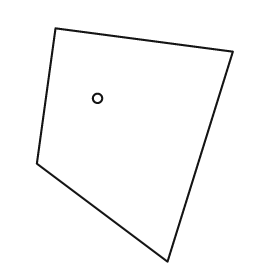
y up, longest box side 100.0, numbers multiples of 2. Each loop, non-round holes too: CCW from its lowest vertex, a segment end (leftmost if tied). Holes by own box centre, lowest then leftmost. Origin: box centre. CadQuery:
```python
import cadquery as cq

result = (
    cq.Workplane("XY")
    .moveTo(14.0, -50.0)
    .lineTo(42.0, 40.0)
    .lineTo(-34.0, 50.0)
    .lineTo(-42.0, -8.0)
    .close()
    .moveTo(-16.0, 20.0)
    .circle(2.0)
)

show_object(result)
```